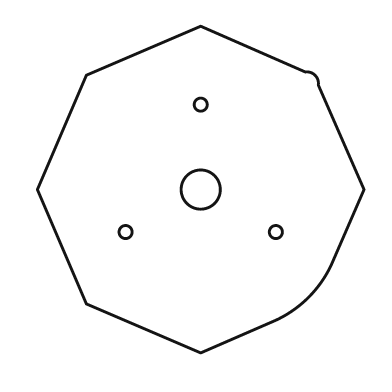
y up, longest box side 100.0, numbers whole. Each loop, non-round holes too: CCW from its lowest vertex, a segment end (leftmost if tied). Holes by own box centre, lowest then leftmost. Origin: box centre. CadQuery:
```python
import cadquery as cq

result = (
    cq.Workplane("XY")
    .moveTo(0.0, -50.0)
    .lineTo(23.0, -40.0)
    .threePointArc((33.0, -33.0), (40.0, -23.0))
    .lineTo(50.0, 0.0)
    .lineTo(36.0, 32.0)
    .threePointArc((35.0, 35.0), (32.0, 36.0))
    .lineTo(0.0, 50.0)
    .lineTo(-35.0, 35.0)
    .lineTo(-50.0, 0.0)
    .lineTo(-35.0, -35.0)
    .close()
    .moveTo(-23.0, -13.0)
    .circle(2.0)
    .moveTo(23.0, -13.0)
    .circle(2.0)
    .moveTo(0.0, 0.0)
    .circle(6.0)
    .moveTo(0.0, 26.0)
    .circle(2.0)
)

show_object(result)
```